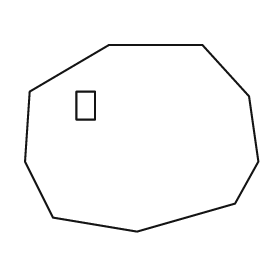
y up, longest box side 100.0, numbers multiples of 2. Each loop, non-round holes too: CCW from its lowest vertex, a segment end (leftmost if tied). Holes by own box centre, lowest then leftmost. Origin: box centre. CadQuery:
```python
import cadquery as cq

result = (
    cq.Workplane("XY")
    .moveTo(-2.0, -40.0)
    .lineTo(40.0, -28.0)
    .lineTo(50.0, -10.0)
    .lineTo(46.0, 18.0)
    .lineTo(26.0, 40.0)
    .lineTo(-14.0, 40.0)
    .lineTo(-48.0, 20.0)
    .lineTo(-50.0, -10.0)
    .lineTo(-38.0, -34.0)
    .close()
    .moveTo(-28.0, 8.0)
    .lineTo(-20.0, 8.0)
    .lineTo(-20.0, 20.0)
    .lineTo(-28.0, 20.0)
    .close()
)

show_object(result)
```